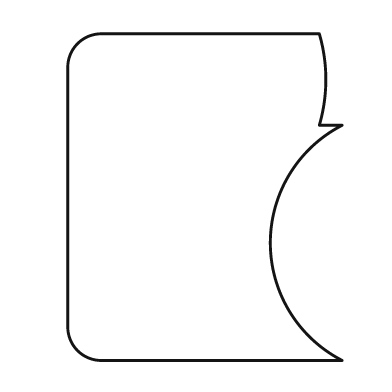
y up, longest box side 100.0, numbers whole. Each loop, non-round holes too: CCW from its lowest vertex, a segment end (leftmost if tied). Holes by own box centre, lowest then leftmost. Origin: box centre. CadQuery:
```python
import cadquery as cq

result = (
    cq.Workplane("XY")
    .moveTo(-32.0, -50.0)
    .lineTo(42.0, -50.0)
    .threePointArc((20.0, -14.0), (42.0, 22.0))
    .lineTo(35.0, 22.0)
    .threePointArc((37.0, 36.0), (35.0, 50.0))
    .lineTo(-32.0, 50.0)
    .threePointArc((-39.0, 47.0), (-42.0, 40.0))
    .lineTo(-42.0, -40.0)
    .threePointArc((-39.0, -47.0), (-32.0, -50.0))
    .close()
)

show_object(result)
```